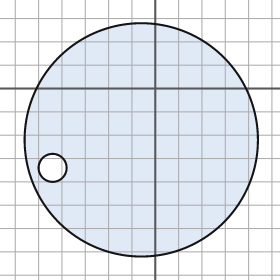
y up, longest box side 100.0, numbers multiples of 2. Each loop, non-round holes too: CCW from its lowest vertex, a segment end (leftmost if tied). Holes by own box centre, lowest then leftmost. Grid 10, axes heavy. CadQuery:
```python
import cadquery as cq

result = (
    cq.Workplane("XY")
    .moveTo(-6.0, -22.0)
    .circle(50.0)
    .moveTo(-44.0, -34.0)
    .circle(6.0)
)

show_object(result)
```